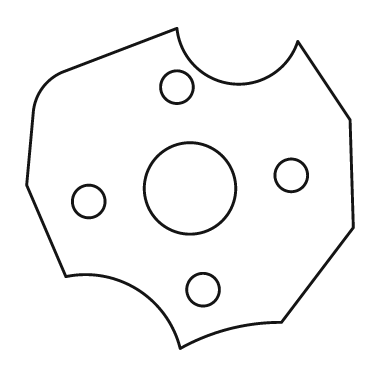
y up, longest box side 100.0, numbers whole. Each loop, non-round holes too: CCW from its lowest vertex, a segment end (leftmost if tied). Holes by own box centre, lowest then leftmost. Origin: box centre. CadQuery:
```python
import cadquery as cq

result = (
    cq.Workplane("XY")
    .moveTo(-3.0, -49.0)
    .threePointArc((12.0, -43.0), (28.0, -41.0))
    .lineTo(50.0, -12.0)
    .lineTo(49.0, 21.0)
    .lineTo(33.0, 45.0)
    .threePointArc((13.0, 32.0), (-4.0, 49.0))
    .lineTo(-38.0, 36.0)
    .threePointArc((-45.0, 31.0), (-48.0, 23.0))
    .lineTo(-50.0, 1.0)
    .lineTo(-38.0, -27.0)
    .threePointArc((-16.0, -31.0), (-3.0, -49.0))
    .close()
    .moveTo(4.0, -31.0)
    .circle(5.0)
    .moveTo(-31.0, -4.0)
    .circle(5.0)
    .moveTo(0.0, 0.0)
    .circle(14.0)
    .moveTo(31.0, 4.0)
    .circle(5.0)
    .moveTo(-4.0, 31.0)
    .circle(5.0)
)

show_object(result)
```